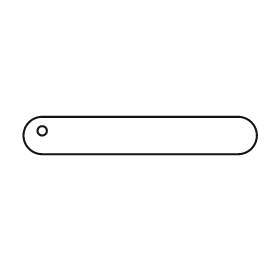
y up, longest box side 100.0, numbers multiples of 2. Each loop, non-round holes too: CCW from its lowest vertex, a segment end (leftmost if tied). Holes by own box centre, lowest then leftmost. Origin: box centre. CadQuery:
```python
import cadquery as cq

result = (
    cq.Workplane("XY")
    .moveTo(-42.0, -8.0)
    .lineTo(42.0, -8.0)
    .threePointArc((50.0, 0.0), (42.0, 8.0))
    .lineTo(-42.0, 8.0)
    .threePointArc((-50.0, 0.0), (-42.0, -8.0))
    .close()
    .moveTo(-42.0, 2.0)
    .circle(2.0)
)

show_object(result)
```